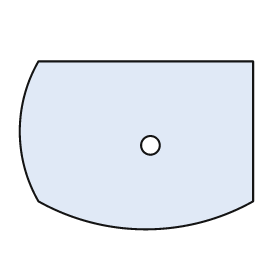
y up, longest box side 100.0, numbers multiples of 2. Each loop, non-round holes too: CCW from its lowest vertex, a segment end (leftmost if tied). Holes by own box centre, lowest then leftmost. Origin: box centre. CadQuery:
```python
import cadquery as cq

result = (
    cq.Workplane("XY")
    .moveTo(-42.0, -24.0)
    .threePointArc((4.0, -36.0), (50.0, -24.0))
    .lineTo(50.0, 36.0)
    .lineTo(-42.0, 36.0)
    .threePointArc((-50.0, 6.0), (-42.0, -24.0))
    .close()
    .moveTo(6.0, 0.0)
    .circle(4.0)
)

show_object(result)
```